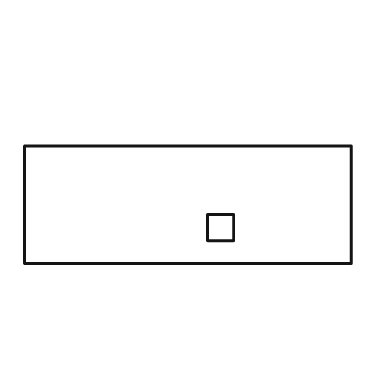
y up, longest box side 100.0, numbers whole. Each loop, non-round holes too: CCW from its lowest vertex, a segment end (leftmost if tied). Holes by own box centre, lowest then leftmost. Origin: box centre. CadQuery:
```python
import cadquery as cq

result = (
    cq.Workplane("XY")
    .moveTo(-50.0, -18.0)
    .lineTo(50.0, -18.0)
    .lineTo(50.0, 18.0)
    .lineTo(-50.0, 18.0)
    .close()
    .moveTo(6.0, -11.0)
    .lineTo(14.0, -11.0)
    .lineTo(14.0, -3.0)
    .lineTo(6.0, -3.0)
    .close()
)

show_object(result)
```